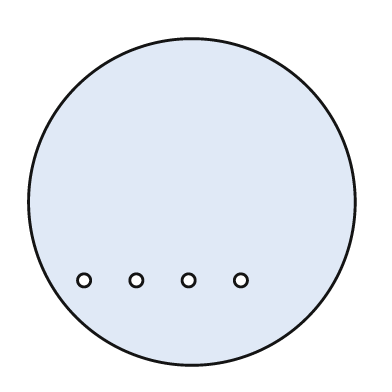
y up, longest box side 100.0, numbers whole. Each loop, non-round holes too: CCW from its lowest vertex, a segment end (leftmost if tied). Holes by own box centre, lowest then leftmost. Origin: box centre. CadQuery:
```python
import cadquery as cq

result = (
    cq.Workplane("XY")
    .moveTo(0.0, 0.0)
    .circle(50.0)
    .moveTo(-33.0, -24.0)
    .circle(2.0)
    .moveTo(-17.0, -24.0)
    .circle(2.0)
    .moveTo(-1.0, -24.0)
    .circle(2.0)
    .moveTo(15.0, -24.0)
    .circle(2.0)
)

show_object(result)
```